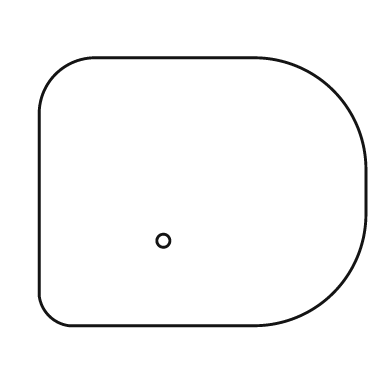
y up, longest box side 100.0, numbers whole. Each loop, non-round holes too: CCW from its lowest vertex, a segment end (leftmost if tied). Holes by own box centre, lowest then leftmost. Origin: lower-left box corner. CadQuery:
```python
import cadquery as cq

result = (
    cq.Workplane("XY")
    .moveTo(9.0, 0.0)
    .lineTo(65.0, 0.0)
    .threePointArc((90.0, 10.0), (100.0, 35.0))
    .lineTo(100.0, 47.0)
    .threePointArc((90.0, 72.0), (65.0, 82.0))
    .lineTo(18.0, 82.0)
    .threePointArc((5.0, 77.0), (0.0, 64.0))
    .lineTo(0.0, 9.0)
    .threePointArc((3.0, 3.0), (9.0, 0.0))
    .close()
    .moveTo(38.0, 26.0)
    .circle(2.0)
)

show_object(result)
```